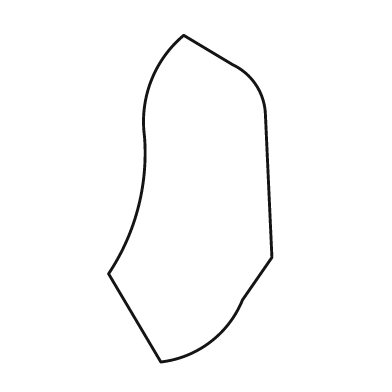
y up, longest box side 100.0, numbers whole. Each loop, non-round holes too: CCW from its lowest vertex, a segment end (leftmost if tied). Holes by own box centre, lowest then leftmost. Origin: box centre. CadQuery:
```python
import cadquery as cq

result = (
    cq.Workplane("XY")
    .moveTo(-9.0, -50.0)
    .threePointArc((6.0, -44.0), (16.0, -31.0))
    .lineTo(25.0, -18.0)
    .lineTo(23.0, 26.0)
    .threePointArc((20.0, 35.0), (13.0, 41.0))
    .lineTo(-2.0, 50.0)
    .threePointArc((-12.0, 36.0), (-14.0, 19.0))
    .threePointArc((-16.0, -3.0), (-25.0, -23.0))
    .close()
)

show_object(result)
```